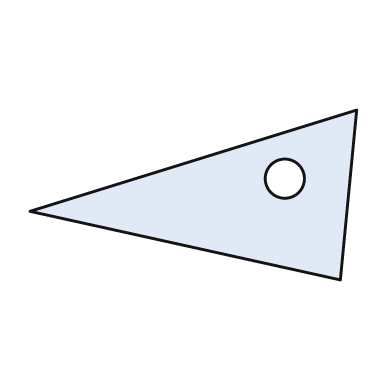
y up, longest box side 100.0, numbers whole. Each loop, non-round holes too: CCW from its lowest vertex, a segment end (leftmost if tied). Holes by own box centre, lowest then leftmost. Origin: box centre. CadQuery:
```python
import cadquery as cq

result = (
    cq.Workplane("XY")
    .moveTo(45.0, -26.0)
    .lineTo(50.0, 26.0)
    .lineTo(-50.0, -5.0)
    .close()
    .moveTo(28.0, 5.0)
    .circle(6.0)
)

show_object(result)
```